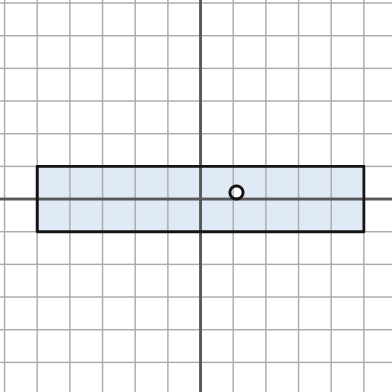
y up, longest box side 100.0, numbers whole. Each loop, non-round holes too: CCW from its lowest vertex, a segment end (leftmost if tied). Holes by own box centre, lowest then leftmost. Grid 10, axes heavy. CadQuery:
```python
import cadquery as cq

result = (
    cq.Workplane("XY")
    .moveTo(-50.0, -10.0)
    .lineTo(50.0, -10.0)
    .lineTo(50.0, 10.0)
    .lineTo(-50.0, 10.0)
    .close()
    .moveTo(11.0, 2.0)
    .circle(2.0)
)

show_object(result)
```